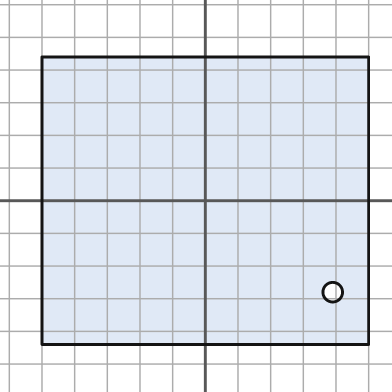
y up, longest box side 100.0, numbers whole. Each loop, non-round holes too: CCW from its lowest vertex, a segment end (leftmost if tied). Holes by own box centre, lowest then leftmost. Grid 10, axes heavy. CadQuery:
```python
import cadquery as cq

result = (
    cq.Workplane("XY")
    .moveTo(-50.0, -44.0)
    .lineTo(50.0, -44.0)
    .lineTo(50.0, 44.0)
    .lineTo(-50.0, 44.0)
    .close()
    .moveTo(39.0, -28.0)
    .circle(3.0)
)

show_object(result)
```